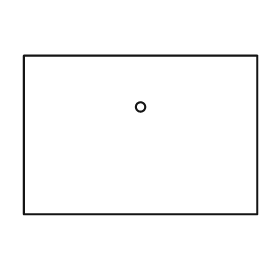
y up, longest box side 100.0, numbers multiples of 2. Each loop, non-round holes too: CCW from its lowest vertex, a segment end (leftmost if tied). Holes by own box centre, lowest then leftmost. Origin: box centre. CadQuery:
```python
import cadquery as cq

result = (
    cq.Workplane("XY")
    .moveTo(-50.0, -34.0)
    .lineTo(50.0, -34.0)
    .lineTo(50.0, 34.0)
    .lineTo(-50.0, 34.0)
    .close()
    .moveTo(0.0, 12.0)
    .circle(2.0)
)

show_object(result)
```